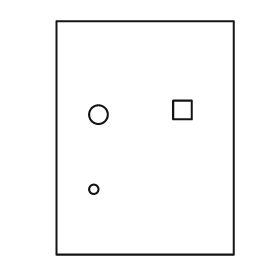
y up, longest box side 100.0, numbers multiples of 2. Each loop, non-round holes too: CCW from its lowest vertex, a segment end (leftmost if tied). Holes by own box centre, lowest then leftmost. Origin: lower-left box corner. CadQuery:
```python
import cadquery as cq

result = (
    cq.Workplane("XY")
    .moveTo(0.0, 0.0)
    .lineTo(76.0, 0.0)
    .lineTo(76.0, 100.0)
    .lineTo(0.0, 100.0)
    .close()
    .moveTo(16.0, 28.0)
    .circle(2.0)
    .moveTo(18.0, 60.0)
    .circle(4.0)
    .moveTo(50.0, 58.0)
    .lineTo(58.0, 58.0)
    .lineTo(58.0, 66.0)
    .lineTo(50.0, 66.0)
    .close()
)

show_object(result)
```